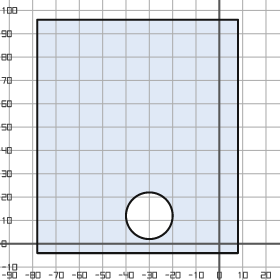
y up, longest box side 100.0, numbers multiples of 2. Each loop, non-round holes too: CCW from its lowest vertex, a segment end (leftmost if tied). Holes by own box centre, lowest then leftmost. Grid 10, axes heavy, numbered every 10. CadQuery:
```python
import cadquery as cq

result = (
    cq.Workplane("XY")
    .moveTo(-78.0, -4.0)
    .lineTo(8.0, -4.0)
    .lineTo(8.0, 96.0)
    .lineTo(-78.0, 96.0)
    .close()
    .moveTo(-30.0, 12.0)
    .circle(10.0)
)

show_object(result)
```